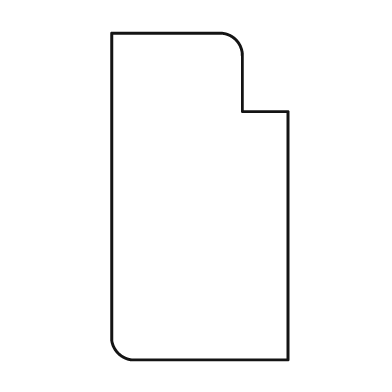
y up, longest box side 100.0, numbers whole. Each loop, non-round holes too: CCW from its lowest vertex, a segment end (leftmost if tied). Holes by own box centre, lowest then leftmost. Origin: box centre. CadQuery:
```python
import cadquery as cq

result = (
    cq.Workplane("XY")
    .moveTo(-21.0, -50.0)
    .lineTo(27.0, -50.0)
    .lineTo(27.0, 26.0)
    .lineTo(13.0, 26.0)
    .lineTo(13.0, 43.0)
    .threePointArc((11.0, 48.0), (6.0, 50.0))
    .lineTo(-27.0, 50.0)
    .lineTo(-27.0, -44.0)
    .threePointArc((-25.0, -48.0), (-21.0, -50.0))
    .close()
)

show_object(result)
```